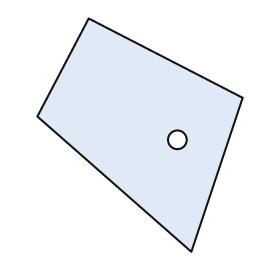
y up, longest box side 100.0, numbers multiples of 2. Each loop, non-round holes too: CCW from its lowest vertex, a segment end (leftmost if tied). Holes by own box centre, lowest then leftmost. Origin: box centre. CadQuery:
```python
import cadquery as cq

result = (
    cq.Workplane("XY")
    .moveTo(22.0, -50.0)
    .lineTo(44.0, 16.0)
    .lineTo(-22.0, 50.0)
    .lineTo(-44.0, 8.0)
    .close()
    .moveTo(16.0, -2.0)
    .circle(4.0)
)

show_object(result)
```